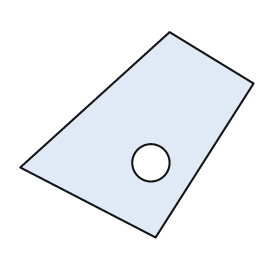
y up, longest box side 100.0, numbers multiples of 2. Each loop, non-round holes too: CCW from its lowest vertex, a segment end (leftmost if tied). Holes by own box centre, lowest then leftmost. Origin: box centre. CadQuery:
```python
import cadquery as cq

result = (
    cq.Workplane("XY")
    .moveTo(8.0, -44.0)
    .lineTo(50.0, 22.0)
    .lineTo(14.0, 44.0)
    .lineTo(-50.0, -14.0)
    .close()
    .moveTo(6.0, -12.0)
    .circle(8.0)
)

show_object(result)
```